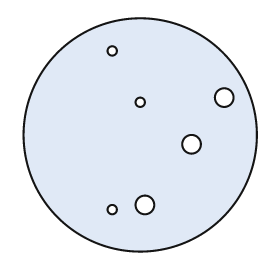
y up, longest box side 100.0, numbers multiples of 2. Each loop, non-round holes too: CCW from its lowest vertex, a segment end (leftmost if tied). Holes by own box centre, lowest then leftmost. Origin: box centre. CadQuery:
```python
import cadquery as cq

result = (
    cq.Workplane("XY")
    .moveTo(0.0, 0.0)
    .circle(50.0)
    .moveTo(-12.0, -32.0)
    .circle(2.0)
    .moveTo(2.0, -30.0)
    .circle(4.0)
    .moveTo(22.0, -4.0)
    .circle(4.0)
    .moveTo(0.0, 14.0)
    .circle(2.0)
    .moveTo(36.0, 16.0)
    .circle(4.0)
    .moveTo(-12.0, 36.0)
    .circle(2.0)
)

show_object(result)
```